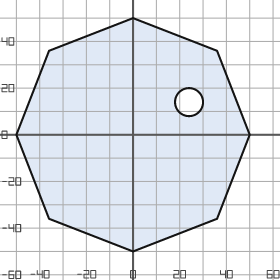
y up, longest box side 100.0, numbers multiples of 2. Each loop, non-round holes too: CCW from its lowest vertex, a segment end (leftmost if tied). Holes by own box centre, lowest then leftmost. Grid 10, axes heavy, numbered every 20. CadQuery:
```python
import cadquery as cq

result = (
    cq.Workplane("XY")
    .moveTo(0.0, -50.0)
    .lineTo(36.0, -36.0)
    .lineTo(50.0, 0.0)
    .lineTo(36.0, 36.0)
    .lineTo(0.0, 50.0)
    .lineTo(-36.0, 36.0)
    .lineTo(-50.0, 0.0)
    .lineTo(-36.0, -36.0)
    .close()
    .moveTo(24.0, 14.0)
    .circle(6.0)
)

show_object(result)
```